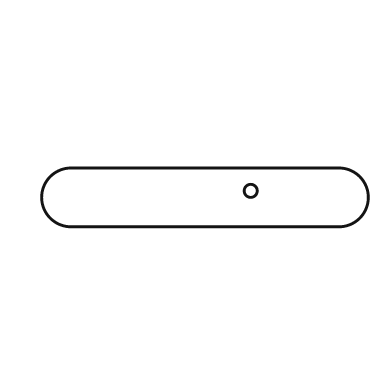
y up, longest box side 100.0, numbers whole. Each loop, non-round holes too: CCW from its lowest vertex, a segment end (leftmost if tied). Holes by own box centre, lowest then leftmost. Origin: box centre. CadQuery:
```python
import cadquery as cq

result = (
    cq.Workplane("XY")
    .moveTo(-41.0, -9.0)
    .lineTo(41.0, -9.0)
    .threePointArc((50.0, 0.0), (41.0, 9.0))
    .lineTo(-41.0, 9.0)
    .threePointArc((-50.0, 0.0), (-41.0, -9.0))
    .close()
    .moveTo(14.0, 2.0)
    .circle(2.0)
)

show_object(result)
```